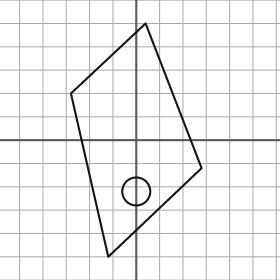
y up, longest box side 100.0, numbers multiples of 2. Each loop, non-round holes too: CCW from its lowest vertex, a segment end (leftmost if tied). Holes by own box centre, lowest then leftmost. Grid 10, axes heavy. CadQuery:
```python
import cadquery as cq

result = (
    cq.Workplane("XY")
    .moveTo(-12.0, -50.0)
    .lineTo(28.0, -12.0)
    .lineTo(4.0, 50.0)
    .lineTo(-28.0, 20.0)
    .close()
    .moveTo(0.0, -22.0)
    .circle(6.0)
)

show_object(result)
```